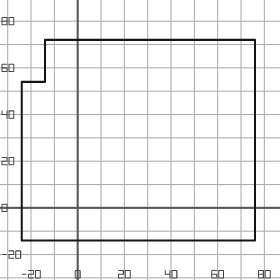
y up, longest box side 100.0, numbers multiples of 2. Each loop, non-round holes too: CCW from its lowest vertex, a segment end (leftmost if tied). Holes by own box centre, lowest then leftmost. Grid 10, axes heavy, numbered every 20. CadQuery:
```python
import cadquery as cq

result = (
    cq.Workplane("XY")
    .moveTo(-24.0, -14.0)
    .lineTo(76.0, -14.0)
    .lineTo(76.0, 72.0)
    .lineTo(-14.0, 72.0)
    .lineTo(-14.0, 54.0)
    .lineTo(-24.0, 54.0)
    .close()
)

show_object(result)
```